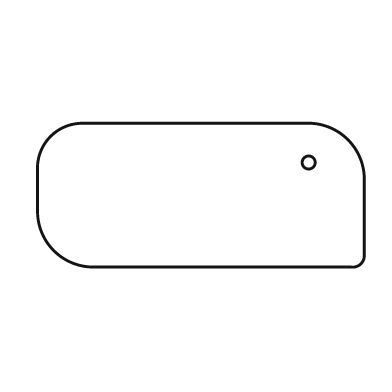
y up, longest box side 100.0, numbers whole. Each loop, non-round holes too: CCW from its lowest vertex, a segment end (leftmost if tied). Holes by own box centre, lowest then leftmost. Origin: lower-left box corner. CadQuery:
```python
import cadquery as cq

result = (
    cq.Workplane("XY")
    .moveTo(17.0, 0.0)
    .lineTo(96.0, 0.0)
    .threePointArc((99.0, 1.0), (100.0, 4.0))
    .lineTo(100.0, 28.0)
    .threePointArc((95.0, 39.0), (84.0, 44.0))
    .lineTo(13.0, 44.0)
    .threePointArc((4.0, 40.0), (0.0, 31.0))
    .lineTo(0.0, 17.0)
    .threePointArc((5.0, 5.0), (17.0, 0.0))
    .close()
    .moveTo(83.0, 32.0)
    .circle(2.0)
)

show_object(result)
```